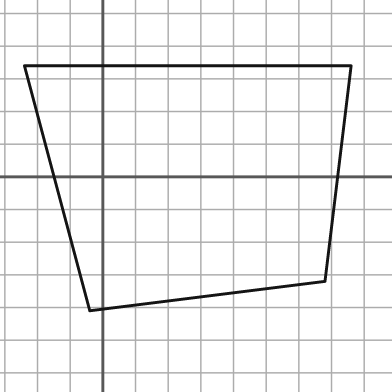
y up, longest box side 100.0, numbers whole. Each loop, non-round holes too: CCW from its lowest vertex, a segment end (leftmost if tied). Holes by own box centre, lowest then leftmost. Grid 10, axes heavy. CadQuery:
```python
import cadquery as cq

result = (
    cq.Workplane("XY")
    .moveTo(-4.0, -41.0)
    .lineTo(68.0, -32.0)
    .lineTo(76.0, 34.0)
    .lineTo(-24.0, 34.0)
    .close()
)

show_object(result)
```